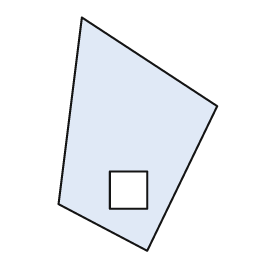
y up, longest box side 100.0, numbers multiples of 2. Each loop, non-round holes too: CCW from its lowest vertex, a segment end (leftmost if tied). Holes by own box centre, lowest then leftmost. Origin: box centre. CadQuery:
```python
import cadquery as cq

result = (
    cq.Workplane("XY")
    .moveTo(4.0, -50.0)
    .lineTo(34.0, 12.0)
    .lineTo(-24.0, 50.0)
    .lineTo(-34.0, -30.0)
    .close()
    .moveTo(-12.0, -32.0)
    .lineTo(4.0, -32.0)
    .lineTo(4.0, -16.0)
    .lineTo(-12.0, -16.0)
    .close()
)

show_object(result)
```